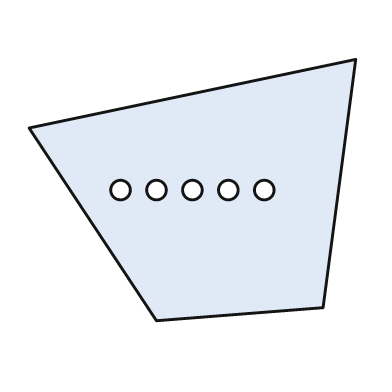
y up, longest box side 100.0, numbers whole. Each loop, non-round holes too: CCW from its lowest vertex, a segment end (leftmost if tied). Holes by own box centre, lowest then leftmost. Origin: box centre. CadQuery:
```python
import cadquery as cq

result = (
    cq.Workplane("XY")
    .moveTo(-11.0, -40.0)
    .lineTo(40.0, -36.0)
    .lineTo(50.0, 40.0)
    .lineTo(-50.0, 19.0)
    .close()
    .moveTo(-22.0, 0.0)
    .circle(3.0)
    .moveTo(-11.0, 0.0)
    .circle(3.0)
    .moveTo(0.0, 0.0)
    .circle(3.0)
    .moveTo(11.0, 0.0)
    .circle(3.0)
    .moveTo(22.0, 0.0)
    .circle(3.0)
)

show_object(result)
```